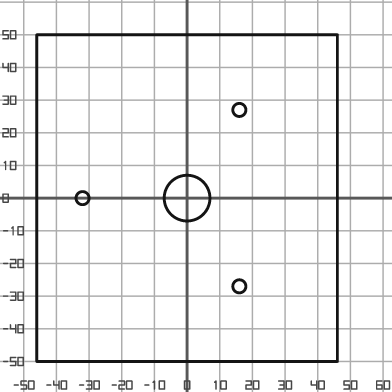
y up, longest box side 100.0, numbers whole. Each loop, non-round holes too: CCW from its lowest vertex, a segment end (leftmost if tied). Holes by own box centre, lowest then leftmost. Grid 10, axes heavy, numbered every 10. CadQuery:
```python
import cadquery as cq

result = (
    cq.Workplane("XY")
    .moveTo(-46.0, -50.0)
    .lineTo(46.0, -50.0)
    .lineTo(46.0, 50.0)
    .lineTo(-46.0, 50.0)
    .close()
    .moveTo(16.0, -27.0)
    .circle(2.0)
    .moveTo(-32.0, 0.0)
    .circle(2.0)
    .moveTo(0.0, 0.0)
    .circle(7.0)
    .moveTo(16.0, 27.0)
    .circle(2.0)
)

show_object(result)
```